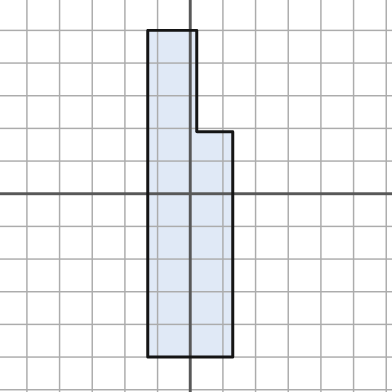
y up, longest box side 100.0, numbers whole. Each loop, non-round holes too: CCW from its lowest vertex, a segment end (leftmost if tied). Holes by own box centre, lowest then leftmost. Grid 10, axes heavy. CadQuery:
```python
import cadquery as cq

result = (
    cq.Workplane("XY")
    .moveTo(-13.0, -50.0)
    .lineTo(13.0, -50.0)
    .lineTo(13.0, 19.0)
    .lineTo(2.0, 19.0)
    .lineTo(2.0, 50.0)
    .lineTo(-13.0, 50.0)
    .close()
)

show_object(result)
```